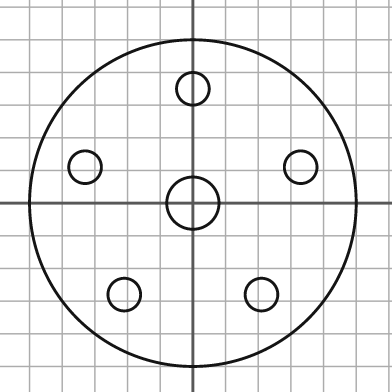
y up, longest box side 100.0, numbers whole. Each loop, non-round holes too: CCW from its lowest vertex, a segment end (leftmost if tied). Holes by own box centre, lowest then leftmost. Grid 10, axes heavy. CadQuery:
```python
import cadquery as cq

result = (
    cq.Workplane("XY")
    .moveTo(0.0, 0.0)
    .circle(50.0)
    .moveTo(-21.0, -28.0)
    .circle(5.0)
    .moveTo(21.0, -28.0)
    .circle(5.0)
    .moveTo(0.0, 0.0)
    .circle(8.0)
    .moveTo(-33.0, 11.0)
    .circle(5.0)
    .moveTo(33.0, 11.0)
    .circle(5.0)
    .moveTo(0.0, 35.0)
    .circle(5.0)
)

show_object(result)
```